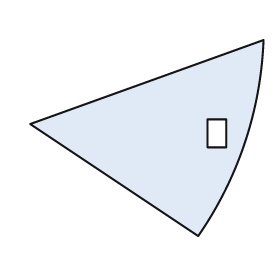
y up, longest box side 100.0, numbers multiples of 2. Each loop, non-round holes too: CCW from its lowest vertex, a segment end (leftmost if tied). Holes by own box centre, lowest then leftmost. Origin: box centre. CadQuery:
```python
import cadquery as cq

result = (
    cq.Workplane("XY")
    .moveTo(22.0, -42.0)
    .threePointArc((42.0, -2.0), (50.0, 42.0))
    .lineTo(-50.0, 6.0)
    .close()
    .moveTo(26.0, -4.0)
    .lineTo(34.0, -4.0)
    .lineTo(34.0, 8.0)
    .lineTo(26.0, 8.0)
    .close()
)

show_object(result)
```